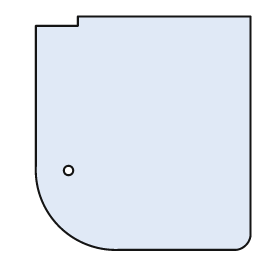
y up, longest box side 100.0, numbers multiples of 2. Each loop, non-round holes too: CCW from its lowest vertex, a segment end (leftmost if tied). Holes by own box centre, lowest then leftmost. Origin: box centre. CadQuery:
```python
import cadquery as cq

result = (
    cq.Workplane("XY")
    .moveTo(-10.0, -50.0)
    .lineTo(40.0, -50.0)
    .threePointArc((44.0, -48.0), (46.0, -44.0))
    .lineTo(46.0, 50.0)
    .lineTo(-28.0, 50.0)
    .lineTo(-28.0, 46.0)
    .lineTo(-46.0, 46.0)
    .lineTo(-46.0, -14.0)
    .threePointArc((-36.0, -40.0), (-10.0, -50.0))
    .close()
    .moveTo(-32.0, -16.0)
    .circle(2.0)
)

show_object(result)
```